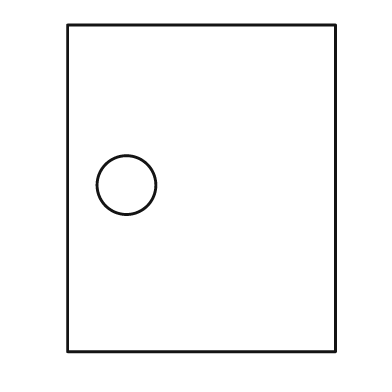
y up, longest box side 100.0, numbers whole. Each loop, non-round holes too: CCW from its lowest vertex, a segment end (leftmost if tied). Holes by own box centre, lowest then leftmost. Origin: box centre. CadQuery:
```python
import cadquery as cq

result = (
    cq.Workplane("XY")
    .moveTo(-41.0, -50.0)
    .lineTo(41.0, -50.0)
    .lineTo(41.0, 50.0)
    .lineTo(-41.0, 50.0)
    .close()
    .moveTo(-23.0, 1.0)
    .circle(9.0)
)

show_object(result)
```